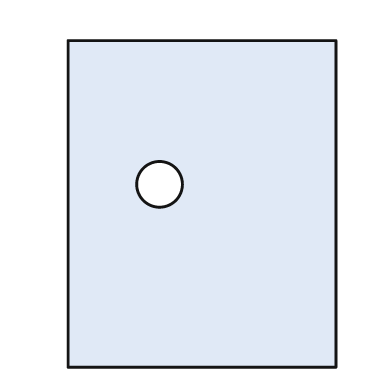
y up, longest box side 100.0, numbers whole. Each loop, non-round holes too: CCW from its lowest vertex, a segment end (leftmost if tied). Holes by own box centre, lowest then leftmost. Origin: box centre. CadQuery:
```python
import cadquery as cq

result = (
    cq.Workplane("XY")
    .moveTo(-41.0, -50.0)
    .lineTo(41.0, -50.0)
    .lineTo(41.0, 50.0)
    .lineTo(-41.0, 50.0)
    .close()
    .moveTo(-13.0, 6.0)
    .circle(7.0)
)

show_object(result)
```